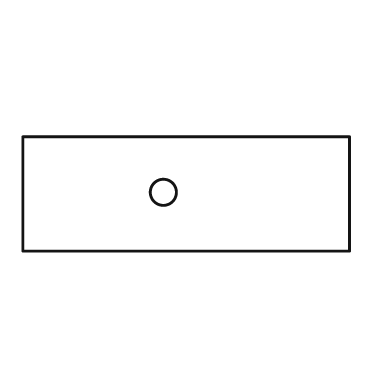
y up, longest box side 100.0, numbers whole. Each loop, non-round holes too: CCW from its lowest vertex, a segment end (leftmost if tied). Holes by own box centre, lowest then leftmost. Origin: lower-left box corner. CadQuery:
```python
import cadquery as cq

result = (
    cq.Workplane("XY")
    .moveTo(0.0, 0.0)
    .lineTo(100.0, 0.0)
    .lineTo(100.0, 35.0)
    .lineTo(0.0, 35.0)
    .close()
    .moveTo(43.0, 18.0)
    .circle(4.0)
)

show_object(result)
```